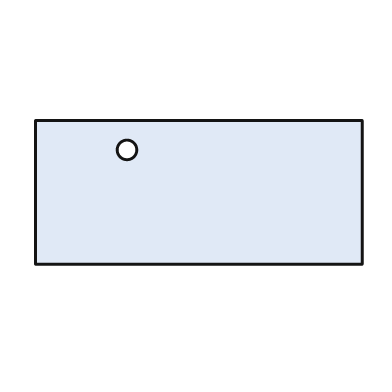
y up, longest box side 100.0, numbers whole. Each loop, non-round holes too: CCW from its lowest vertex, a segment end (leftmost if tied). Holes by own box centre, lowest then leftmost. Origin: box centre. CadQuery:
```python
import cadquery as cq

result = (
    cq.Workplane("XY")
    .moveTo(-50.0, -22.0)
    .lineTo(50.0, -22.0)
    .lineTo(50.0, 22.0)
    .lineTo(-50.0, 22.0)
    .close()
    .moveTo(-22.0, 13.0)
    .circle(3.0)
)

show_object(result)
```